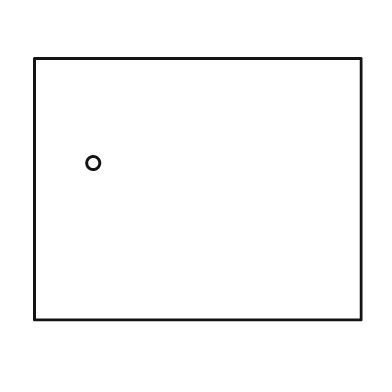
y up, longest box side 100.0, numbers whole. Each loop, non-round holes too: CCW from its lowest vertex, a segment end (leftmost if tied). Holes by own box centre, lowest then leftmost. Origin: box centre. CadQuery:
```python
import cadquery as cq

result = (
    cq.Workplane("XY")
    .moveTo(-50.0, -40.0)
    .lineTo(50.0, -40.0)
    .lineTo(50.0, 40.0)
    .lineTo(-50.0, 40.0)
    .close()
    .moveTo(-32.0, 8.0)
    .circle(2.0)
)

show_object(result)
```